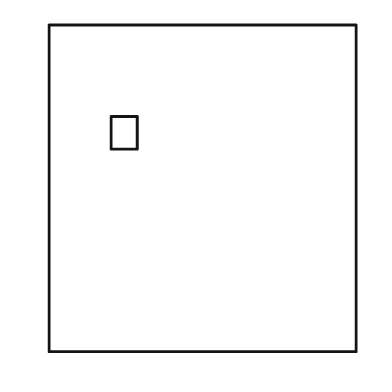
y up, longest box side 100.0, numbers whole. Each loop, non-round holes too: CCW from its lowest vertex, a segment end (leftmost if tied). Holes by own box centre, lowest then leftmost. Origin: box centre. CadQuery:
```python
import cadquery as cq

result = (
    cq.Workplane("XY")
    .moveTo(-47.0, -50.0)
    .lineTo(47.0, -50.0)
    .lineTo(47.0, 50.0)
    .lineTo(-47.0, 50.0)
    .close()
    .moveTo(-28.0, 12.0)
    .lineTo(-20.0, 12.0)
    .lineTo(-20.0, 22.0)
    .lineTo(-28.0, 22.0)
    .close()
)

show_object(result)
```